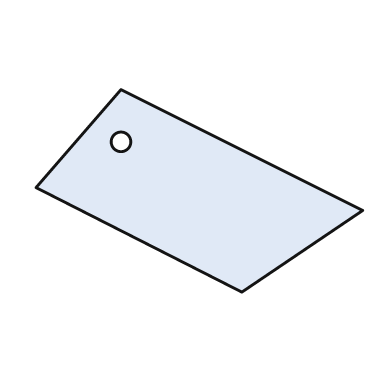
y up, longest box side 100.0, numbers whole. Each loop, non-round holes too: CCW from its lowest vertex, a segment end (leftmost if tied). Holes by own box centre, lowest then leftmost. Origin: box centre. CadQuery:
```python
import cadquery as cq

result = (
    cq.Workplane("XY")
    .moveTo(13.0, -31.0)
    .lineTo(50.0, -6.0)
    .lineTo(-24.0, 31.0)
    .lineTo(-50.0, 1.0)
    .close()
    .moveTo(-24.0, 15.0)
    .circle(3.0)
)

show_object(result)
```